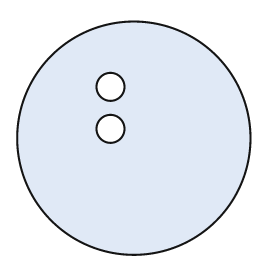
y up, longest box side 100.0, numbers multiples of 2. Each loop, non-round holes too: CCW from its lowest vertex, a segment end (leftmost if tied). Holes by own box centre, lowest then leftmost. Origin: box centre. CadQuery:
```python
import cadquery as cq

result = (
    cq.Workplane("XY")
    .moveTo(0.0, 0.0)
    .circle(50.0)
    .moveTo(-10.0, 4.0)
    .circle(6.0)
    .moveTo(-10.0, 22.0)
    .circle(6.0)
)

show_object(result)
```